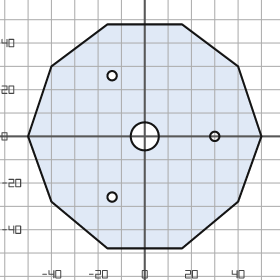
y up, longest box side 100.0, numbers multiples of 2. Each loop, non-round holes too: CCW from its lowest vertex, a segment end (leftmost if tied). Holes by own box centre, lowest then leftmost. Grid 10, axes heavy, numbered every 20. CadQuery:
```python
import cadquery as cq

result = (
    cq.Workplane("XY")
    .moveTo(-16.0, -48.0)
    .lineTo(16.0, -48.0)
    .lineTo(40.0, -28.0)
    .lineTo(50.0, 0.0)
    .lineTo(40.0, 30.0)
    .lineTo(16.0, 48.0)
    .lineTo(-16.0, 48.0)
    .lineTo(-40.0, 30.0)
    .lineTo(-50.0, 0.0)
    .lineTo(-40.0, -28.0)
    .close()
    .moveTo(-14.0, -26.0)
    .circle(2.0)
    .moveTo(0.0, 0.0)
    .circle(6.0)
    .moveTo(30.0, 0.0)
    .circle(2.0)
    .moveTo(-14.0, 26.0)
    .circle(2.0)
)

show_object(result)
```